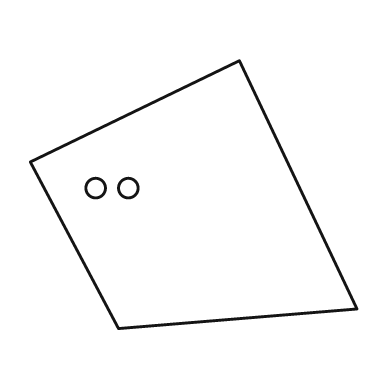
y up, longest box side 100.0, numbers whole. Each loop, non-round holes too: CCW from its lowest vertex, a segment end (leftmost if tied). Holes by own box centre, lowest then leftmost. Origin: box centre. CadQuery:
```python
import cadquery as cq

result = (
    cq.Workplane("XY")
    .moveTo(-23.0, -41.0)
    .lineTo(50.0, -35.0)
    .lineTo(14.0, 41.0)
    .lineTo(-50.0, 10.0)
    .close()
    .moveTo(-30.0, 2.0)
    .circle(3.0)
    .moveTo(-20.0, 2.0)
    .circle(3.0)
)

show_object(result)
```